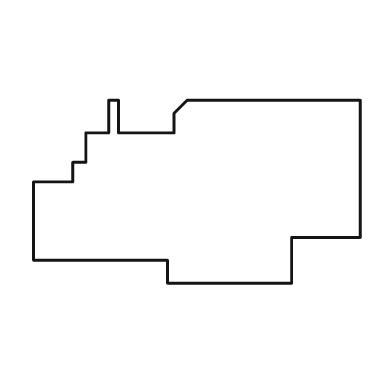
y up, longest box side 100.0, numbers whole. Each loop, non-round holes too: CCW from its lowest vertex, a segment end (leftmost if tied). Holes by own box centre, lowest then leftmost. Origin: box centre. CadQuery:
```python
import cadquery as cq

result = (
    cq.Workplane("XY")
    .moveTo(-9.0, -28.0)
    .lineTo(29.0, -28.0)
    .lineTo(29.0, -14.0)
    .lineTo(50.0, -14.0)
    .lineTo(50.0, 28.0)
    .lineTo(-3.0, 28.0)
    .lineTo(-7.0, 24.0)
    .lineTo(-7.0, 18.0)
    .lineTo(-24.0, 18.0)
    .lineTo(-24.0, 28.0)
    .lineTo(-27.0, 28.0)
    .lineTo(-27.0, 18.0)
    .lineTo(-34.0, 18.0)
    .lineTo(-34.0, 9.0)
    .lineTo(-38.0, 9.0)
    .lineTo(-38.0, 3.0)
    .lineTo(-50.0, 3.0)
    .lineTo(-50.0, -21.0)
    .lineTo(-9.0, -21.0)
    .close()
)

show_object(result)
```